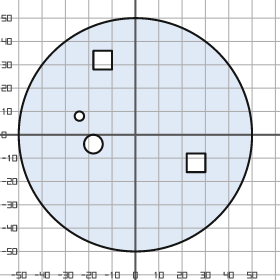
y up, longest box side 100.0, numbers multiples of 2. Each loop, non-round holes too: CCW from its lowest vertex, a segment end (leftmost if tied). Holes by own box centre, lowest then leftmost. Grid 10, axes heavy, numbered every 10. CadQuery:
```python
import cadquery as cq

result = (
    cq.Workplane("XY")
    .moveTo(0.0, 0.0)
    .circle(50.0)
    .moveTo(22.0, -16.0)
    .lineTo(30.0, -16.0)
    .lineTo(30.0, -8.0)
    .lineTo(22.0, -8.0)
    .close()
    .moveTo(-18.0, -4.0)
    .circle(4.0)
    .moveTo(-24.0, 8.0)
    .circle(2.0)
    .moveTo(-18.0, 28.0)
    .lineTo(-10.0, 28.0)
    .lineTo(-10.0, 36.0)
    .lineTo(-18.0, 36.0)
    .close()
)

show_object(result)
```